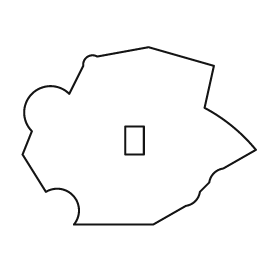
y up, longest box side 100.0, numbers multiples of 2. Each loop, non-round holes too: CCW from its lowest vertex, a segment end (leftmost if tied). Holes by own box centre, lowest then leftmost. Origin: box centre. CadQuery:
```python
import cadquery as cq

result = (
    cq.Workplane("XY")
    .moveTo(-28.0, -38.0)
    .lineTo(6.0, -38.0)
    .lineTo(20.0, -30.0)
    .threePointArc((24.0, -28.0), (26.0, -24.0))
    .lineTo(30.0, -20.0)
    .threePointArc((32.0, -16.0), (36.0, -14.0))
    .lineTo(50.0, -6.0)
    .threePointArc((40.0, 4.0), (28.0, 12.0))
    .lineTo(32.0, 30.0)
    .lineTo(4.0, 38.0)
    .lineTo(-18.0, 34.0)
    .threePointArc((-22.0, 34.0), (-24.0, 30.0))
    .lineTo(-30.0, 18.0)
    .threePointArc((-46.0, 18.0), (-46.0, 2.0))
    .lineTo(-50.0, -8.0)
    .lineTo(-40.0, -24.0)
    .threePointArc((-28.0, -26.0), (-28.0, -38.0))
    .close()
    .moveTo(-6.0, -8.0)
    .lineTo(2.0, -8.0)
    .lineTo(2.0, 4.0)
    .lineTo(-6.0, 4.0)
    .close()
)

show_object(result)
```